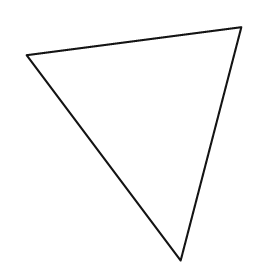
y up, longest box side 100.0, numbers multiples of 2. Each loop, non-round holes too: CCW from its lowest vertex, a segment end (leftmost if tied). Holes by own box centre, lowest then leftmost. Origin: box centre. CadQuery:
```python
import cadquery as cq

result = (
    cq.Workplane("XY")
    .moveTo(20.0, -50.0)
    .lineTo(46.0, 50.0)
    .lineTo(-46.0, 38.0)
    .close()
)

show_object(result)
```